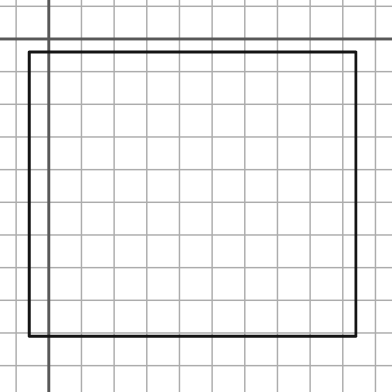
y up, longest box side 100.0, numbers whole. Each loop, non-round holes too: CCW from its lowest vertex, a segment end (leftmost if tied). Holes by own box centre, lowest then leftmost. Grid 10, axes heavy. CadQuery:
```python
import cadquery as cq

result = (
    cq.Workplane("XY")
    .moveTo(-6.0, -91.0)
    .lineTo(94.0, -91.0)
    .lineTo(94.0, -4.0)
    .lineTo(-6.0, -4.0)
    .close()
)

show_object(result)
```